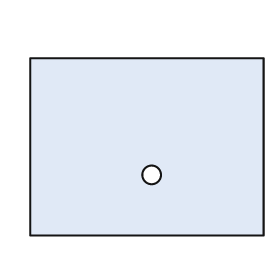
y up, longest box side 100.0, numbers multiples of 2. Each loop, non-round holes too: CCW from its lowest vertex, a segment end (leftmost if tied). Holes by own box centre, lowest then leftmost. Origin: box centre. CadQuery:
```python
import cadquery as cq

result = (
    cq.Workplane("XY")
    .moveTo(-50.0, -38.0)
    .lineTo(50.0, -38.0)
    .lineTo(50.0, 38.0)
    .lineTo(-50.0, 38.0)
    .close()
    .moveTo(2.0, -12.0)
    .circle(4.0)
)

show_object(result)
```